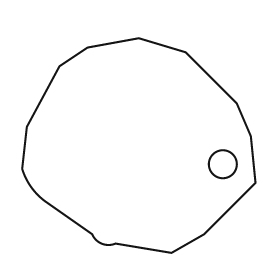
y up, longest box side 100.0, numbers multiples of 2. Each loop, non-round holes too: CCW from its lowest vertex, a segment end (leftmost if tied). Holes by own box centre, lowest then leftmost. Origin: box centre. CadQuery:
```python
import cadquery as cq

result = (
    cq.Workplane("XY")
    .moveTo(14.0, -46.0)
    .lineTo(28.0, -38.0)
    .lineTo(50.0, -16.0)
    .lineTo(48.0, 4.0)
    .lineTo(42.0, 18.0)
    .lineTo(20.0, 40.0)
    .lineTo(0.0, 46.0)
    .lineTo(-22.0, 42.0)
    .lineTo(-34.0, 34.0)
    .lineTo(-48.0, 8.0)
    .lineTo(-50.0, -10.0)
    .threePointArc((-46.0, -18.0), (-40.0, -24.0))
    .lineTo(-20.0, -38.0)
    .threePointArc((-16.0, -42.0), (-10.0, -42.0))
    .close()
    .moveTo(36.0, -8.0)
    .circle(6.0)
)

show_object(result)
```